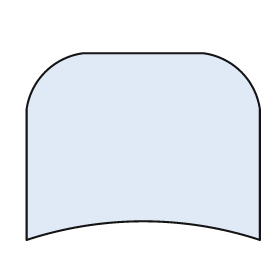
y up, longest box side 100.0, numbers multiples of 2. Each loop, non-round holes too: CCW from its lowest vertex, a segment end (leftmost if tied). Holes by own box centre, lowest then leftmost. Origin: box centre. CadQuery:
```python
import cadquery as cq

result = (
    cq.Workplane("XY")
    .moveTo(-50.0, -40.0)
    .threePointArc((0.0, -32.0), (50.0, -40.0))
    .lineTo(50.0, 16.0)
    .threePointArc((42.0, 32.0), (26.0, 40.0))
    .lineTo(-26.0, 40.0)
    .threePointArc((-42.0, 32.0), (-50.0, 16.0))
    .close()
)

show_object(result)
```